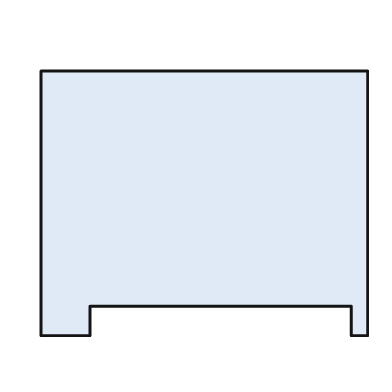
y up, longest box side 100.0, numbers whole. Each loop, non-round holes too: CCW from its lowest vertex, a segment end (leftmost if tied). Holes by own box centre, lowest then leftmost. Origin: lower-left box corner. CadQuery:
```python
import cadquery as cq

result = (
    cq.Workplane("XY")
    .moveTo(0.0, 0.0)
    .lineTo(15.0, 0.0)
    .lineTo(15.0, 9.0)
    .lineTo(95.0, 9.0)
    .lineTo(95.0, 0.0)
    .lineTo(100.0, 0.0)
    .lineTo(100.0, 81.0)
    .lineTo(0.0, 81.0)
    .close()
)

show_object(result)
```